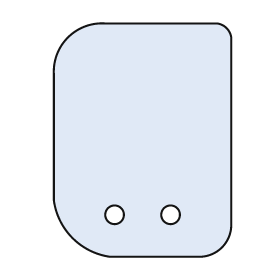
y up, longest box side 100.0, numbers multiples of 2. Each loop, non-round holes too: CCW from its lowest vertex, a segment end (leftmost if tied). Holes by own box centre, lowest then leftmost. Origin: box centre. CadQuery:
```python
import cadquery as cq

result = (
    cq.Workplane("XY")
    .moveTo(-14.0, -50.0)
    .lineTo(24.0, -50.0)
    .threePointArc((34.0, -46.0), (38.0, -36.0))
    .lineTo(38.0, 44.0)
    .threePointArc((36.0, 48.0), (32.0, 50.0))
    .lineTo(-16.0, 50.0)
    .threePointArc((-32.0, 44.0), (-38.0, 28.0))
    .lineTo(-38.0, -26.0)
    .threePointArc((-30.0, -42.0), (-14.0, -50.0))
    .close()
    .moveTo(-12.0, -32.0)
    .circle(4.0)
    .moveTo(12.0, -32.0)
    .circle(4.0)
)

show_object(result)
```